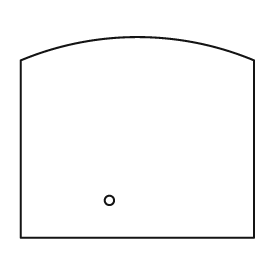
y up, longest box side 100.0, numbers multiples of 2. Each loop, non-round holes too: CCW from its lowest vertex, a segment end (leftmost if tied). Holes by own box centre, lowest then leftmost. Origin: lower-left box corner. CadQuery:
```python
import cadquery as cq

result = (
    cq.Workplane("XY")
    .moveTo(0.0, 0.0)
    .lineTo(100.0, 0.0)
    .lineTo(100.0, 76.0)
    .threePointArc((50.0, 86.0), (0.0, 76.0))
    .close()
    .moveTo(38.0, 16.0)
    .circle(2.0)
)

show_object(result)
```